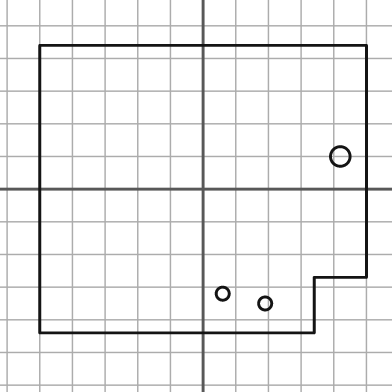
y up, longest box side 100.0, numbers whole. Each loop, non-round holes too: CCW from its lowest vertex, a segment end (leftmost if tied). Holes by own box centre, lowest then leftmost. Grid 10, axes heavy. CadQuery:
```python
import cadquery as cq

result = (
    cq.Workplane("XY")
    .moveTo(-50.0, -44.0)
    .lineTo(34.0, -44.0)
    .lineTo(34.0, -27.0)
    .lineTo(50.0, -27.0)
    .lineTo(50.0, 44.0)
    .lineTo(-50.0, 44.0)
    .close()
    .moveTo(19.0, -35.0)
    .circle(2.0)
    .moveTo(6.0, -32.0)
    .circle(2.0)
    .moveTo(42.0, 10.0)
    .circle(3.0)
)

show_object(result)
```